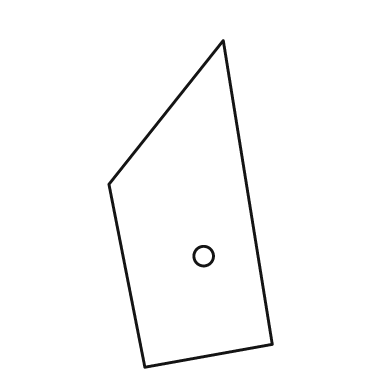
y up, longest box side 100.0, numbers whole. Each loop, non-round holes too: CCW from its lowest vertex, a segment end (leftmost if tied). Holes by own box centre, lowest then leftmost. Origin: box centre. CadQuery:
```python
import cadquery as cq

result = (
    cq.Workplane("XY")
    .moveTo(-14.0, -50.0)
    .lineTo(25.0, -43.0)
    .lineTo(10.0, 50.0)
    .lineTo(-25.0, 6.0)
    .close()
    .moveTo(4.0, -16.0)
    .circle(3.0)
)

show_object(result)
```